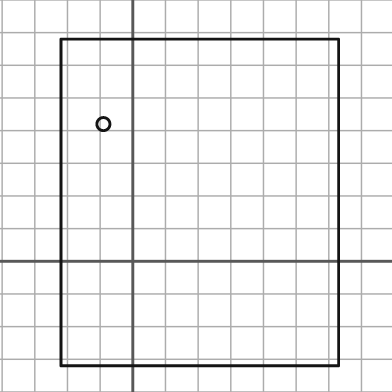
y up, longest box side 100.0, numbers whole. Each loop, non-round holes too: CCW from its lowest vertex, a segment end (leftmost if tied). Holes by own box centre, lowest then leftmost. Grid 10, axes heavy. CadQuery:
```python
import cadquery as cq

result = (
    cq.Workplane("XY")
    .moveTo(-22.0, -32.0)
    .lineTo(63.0, -32.0)
    .lineTo(63.0, 68.0)
    .lineTo(-22.0, 68.0)
    .close()
    .moveTo(-9.0, 42.0)
    .circle(2.0)
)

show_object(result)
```